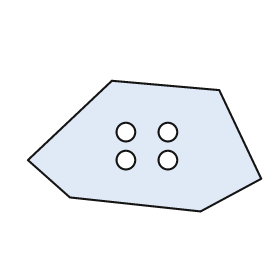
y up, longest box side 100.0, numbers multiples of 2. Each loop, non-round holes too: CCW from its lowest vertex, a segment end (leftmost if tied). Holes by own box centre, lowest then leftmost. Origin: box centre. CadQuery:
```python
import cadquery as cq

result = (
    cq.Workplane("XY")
    .moveTo(24.0, -28.0)
    .lineTo(50.0, -14.0)
    .lineTo(32.0, 24.0)
    .lineTo(-14.0, 28.0)
    .lineTo(-50.0, -6.0)
    .lineTo(-32.0, -22.0)
    .close()
    .moveTo(-8.0, -6.0)
    .circle(4.0)
    .moveTo(10.0, -6.0)
    .circle(4.0)
    .moveTo(-8.0, 6.0)
    .circle(4.0)
    .moveTo(10.0, 6.0)
    .circle(4.0)
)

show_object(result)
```